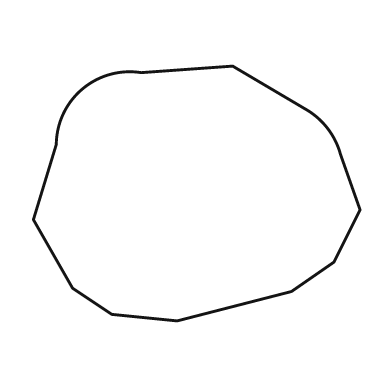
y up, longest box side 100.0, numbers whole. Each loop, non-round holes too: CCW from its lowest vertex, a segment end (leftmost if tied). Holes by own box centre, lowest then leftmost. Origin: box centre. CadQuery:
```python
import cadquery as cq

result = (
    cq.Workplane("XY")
    .moveTo(-6.0, -39.0)
    .lineTo(29.0, -30.0)
    .lineTo(42.0, -21.0)
    .lineTo(50.0, -5.0)
    .lineTo(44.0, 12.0)
    .threePointArc((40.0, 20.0), (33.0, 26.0))
    .lineTo(11.0, 39.0)
    .lineTo(-17.0, 37.0)
    .threePointArc((-35.0, 32.0), (-43.0, 15.0))
    .lineTo(-50.0, -8.0)
    .lineTo(-38.0, -29.0)
    .lineTo(-26.0, -37.0)
    .close()
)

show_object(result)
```